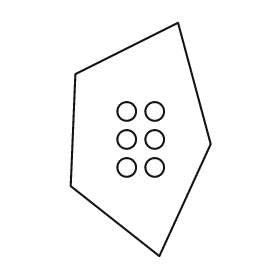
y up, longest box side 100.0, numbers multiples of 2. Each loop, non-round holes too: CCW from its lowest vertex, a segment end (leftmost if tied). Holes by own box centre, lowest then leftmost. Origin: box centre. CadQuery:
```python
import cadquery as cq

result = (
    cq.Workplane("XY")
    .moveTo(8.0, -50.0)
    .lineTo(30.0, -2.0)
    .lineTo(16.0, 50.0)
    .lineTo(-28.0, 28.0)
    .lineTo(-30.0, -20.0)
    .close()
    .moveTo(-6.0, -12.0)
    .circle(4.0)
    .moveTo(6.0, -12.0)
    .circle(4.0)
    .moveTo(-6.0, 0.0)
    .circle(4.0)
    .moveTo(6.0, 0.0)
    .circle(4.0)
    .moveTo(-6.0, 12.0)
    .circle(4.0)
    .moveTo(6.0, 12.0)
    .circle(4.0)
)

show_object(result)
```